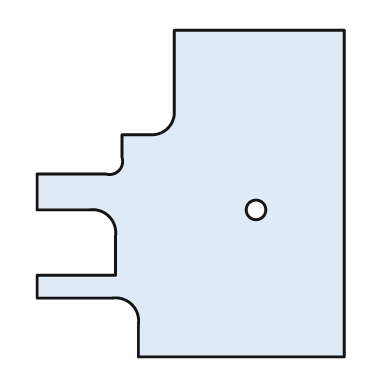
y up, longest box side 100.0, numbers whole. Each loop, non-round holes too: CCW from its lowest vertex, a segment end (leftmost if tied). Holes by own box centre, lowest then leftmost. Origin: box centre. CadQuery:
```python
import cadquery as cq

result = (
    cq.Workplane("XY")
    .moveTo(-16.0, -50.0)
    .lineTo(47.0, -50.0)
    .lineTo(47.0, 50.0)
    .lineTo(-5.0, 50.0)
    .lineTo(-5.0, 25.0)
    .threePointArc((-7.0, 20.0), (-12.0, 18.0))
    .lineTo(-21.0, 18.0)
    .lineTo(-21.0, 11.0)
    .threePointArc((-22.0, 7.0), (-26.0, 6.0))
    .lineTo(-47.0, 6.0)
    .lineTo(-47.0, -5.0)
    .lineTo(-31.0, -5.0)
    .threePointArc((-25.0, -7.0), (-23.0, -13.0))
    .lineTo(-23.0, -25.0)
    .lineTo(-47.0, -25.0)
    .lineTo(-47.0, -32.0)
    .lineTo(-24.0, -32.0)
    .threePointArc((-18.0, -34.0), (-16.0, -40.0))
    .close()
    .moveTo(20.0, -5.0)
    .circle(3.0)
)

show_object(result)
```